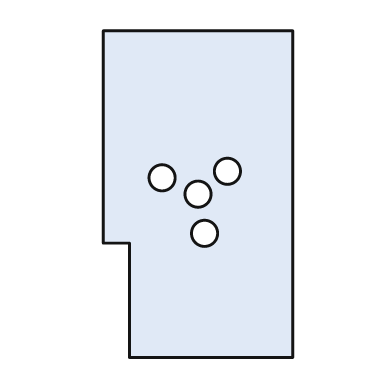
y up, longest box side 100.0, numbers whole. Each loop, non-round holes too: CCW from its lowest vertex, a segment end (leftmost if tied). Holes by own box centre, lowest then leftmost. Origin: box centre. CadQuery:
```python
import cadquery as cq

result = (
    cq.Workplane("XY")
    .moveTo(-21.0, -50.0)
    .lineTo(29.0, -50.0)
    .lineTo(29.0, 50.0)
    .lineTo(-29.0, 50.0)
    .lineTo(-29.0, -15.0)
    .lineTo(-21.0, -15.0)
    .close()
    .moveTo(2.0, -12.0)
    .circle(4.0)
    .moveTo(0.0, 0.0)
    .circle(4.0)
    .moveTo(-11.0, 5.0)
    .circle(4.0)
    .moveTo(9.0, 7.0)
    .circle(4.0)
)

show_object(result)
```